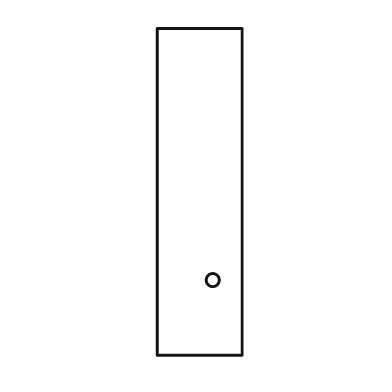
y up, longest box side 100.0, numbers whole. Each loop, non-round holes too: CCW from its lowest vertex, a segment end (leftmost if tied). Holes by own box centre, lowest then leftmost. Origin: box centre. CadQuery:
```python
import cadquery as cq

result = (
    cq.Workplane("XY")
    .moveTo(-13.0, -50.0)
    .lineTo(13.0, -50.0)
    .lineTo(13.0, 50.0)
    .lineTo(-13.0, 50.0)
    .close()
    .moveTo(4.0, -27.0)
    .circle(2.0)
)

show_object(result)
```